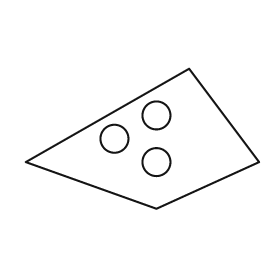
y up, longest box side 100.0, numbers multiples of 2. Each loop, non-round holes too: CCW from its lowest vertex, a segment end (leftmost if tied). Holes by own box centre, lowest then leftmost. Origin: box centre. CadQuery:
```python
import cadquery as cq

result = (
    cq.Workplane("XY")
    .moveTo(6.0, -30.0)
    .lineTo(50.0, -10.0)
    .lineTo(20.0, 30.0)
    .lineTo(-50.0, -10.0)
    .close()
    .moveTo(6.0, -10.0)
    .circle(6.0)
    .moveTo(-12.0, 0.0)
    .circle(6.0)
    .moveTo(6.0, 10.0)
    .circle(6.0)
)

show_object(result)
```